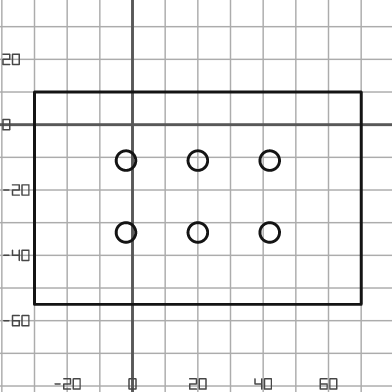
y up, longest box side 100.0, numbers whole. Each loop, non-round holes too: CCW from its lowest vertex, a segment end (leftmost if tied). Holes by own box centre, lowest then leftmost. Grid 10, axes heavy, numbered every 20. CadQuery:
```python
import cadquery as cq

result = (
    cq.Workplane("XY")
    .moveTo(-30.0, -55.0)
    .lineTo(70.0, -55.0)
    .lineTo(70.0, 10.0)
    .lineTo(-30.0, 10.0)
    .close()
    .moveTo(-2.0, -33.0)
    .circle(3.0)
    .moveTo(20.0, -33.0)
    .circle(3.0)
    .moveTo(42.0, -33.0)
    .circle(3.0)
    .moveTo(-2.0, -11.0)
    .circle(3.0)
    .moveTo(20.0, -11.0)
    .circle(3.0)
    .moveTo(42.0, -11.0)
    .circle(3.0)
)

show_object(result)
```